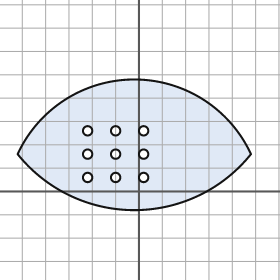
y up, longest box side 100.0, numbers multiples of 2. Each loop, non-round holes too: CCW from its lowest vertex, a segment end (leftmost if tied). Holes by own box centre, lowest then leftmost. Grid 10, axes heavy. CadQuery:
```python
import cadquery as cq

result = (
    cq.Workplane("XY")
    .moveTo(-52.0, 16.0)
    .threePointArc((-2.0, -8.0), (48.0, 16.0))
    .threePointArc((-2.0, 48.0), (-52.0, 16.0))
    .close()
    .moveTo(-22.0, 6.0)
    .circle(2.0)
    .moveTo(-10.0, 6.0)
    .circle(2.0)
    .moveTo(2.0, 6.0)
    .circle(2.0)
    .moveTo(-22.0, 16.0)
    .circle(2.0)
    .moveTo(-10.0, 16.0)
    .circle(2.0)
    .moveTo(2.0, 16.0)
    .circle(2.0)
    .moveTo(-22.0, 26.0)
    .circle(2.0)
    .moveTo(-10.0, 26.0)
    .circle(2.0)
    .moveTo(2.0, 26.0)
    .circle(2.0)
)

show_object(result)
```